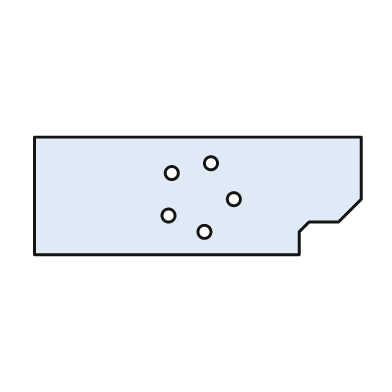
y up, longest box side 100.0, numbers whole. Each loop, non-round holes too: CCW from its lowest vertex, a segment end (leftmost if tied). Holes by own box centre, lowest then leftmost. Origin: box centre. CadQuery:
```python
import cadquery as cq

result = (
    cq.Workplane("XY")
    .moveTo(-50.0, -18.0)
    .lineTo(31.0, -18.0)
    .lineTo(31.0, -11.0)
    .lineTo(34.0, -8.0)
    .lineTo(43.0, -8.0)
    .lineTo(50.0, -1.0)
    .lineTo(50.0, 18.0)
    .lineTo(-50.0, 18.0)
    .close()
    .moveTo(2.0, -11.0)
    .circle(2.0)
    .moveTo(-9.0, -6.0)
    .circle(2.0)
    .moveTo(11.0, -1.0)
    .circle(2.0)
    .moveTo(-8.0, 7.0)
    .circle(2.0)
    .moveTo(4.0, 10.0)
    .circle(2.0)
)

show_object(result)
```